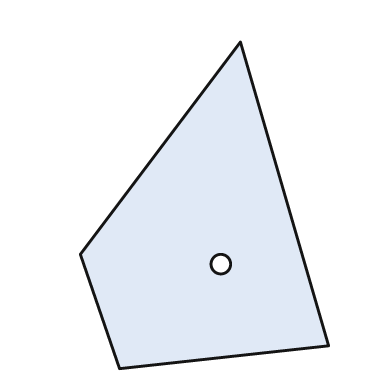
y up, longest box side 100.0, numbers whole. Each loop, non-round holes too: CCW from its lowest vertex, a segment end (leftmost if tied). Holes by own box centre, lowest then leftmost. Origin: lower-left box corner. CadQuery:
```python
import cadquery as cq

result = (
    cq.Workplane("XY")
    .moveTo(12.0, 0.0)
    .lineTo(76.0, 7.0)
    .lineTo(49.0, 100.0)
    .lineTo(0.0, 35.0)
    .close()
    .moveTo(43.0, 32.0)
    .circle(3.0)
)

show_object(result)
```